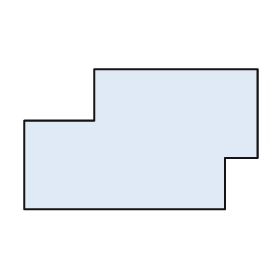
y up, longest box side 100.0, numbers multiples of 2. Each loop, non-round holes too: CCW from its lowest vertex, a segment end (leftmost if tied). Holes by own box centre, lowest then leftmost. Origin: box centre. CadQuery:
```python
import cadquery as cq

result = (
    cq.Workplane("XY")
    .moveTo(-50.0, -30.0)
    .lineTo(36.0, -30.0)
    .lineTo(36.0, -8.0)
    .lineTo(50.0, -8.0)
    .lineTo(50.0, 30.0)
    .lineTo(-20.0, 30.0)
    .lineTo(-20.0, 8.0)
    .lineTo(-50.0, 8.0)
    .close()
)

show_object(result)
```